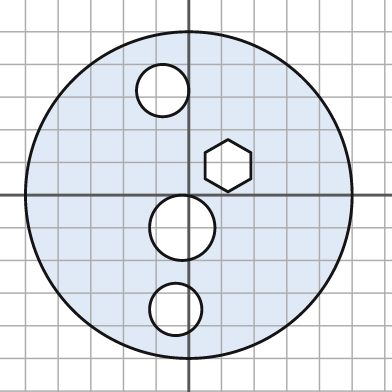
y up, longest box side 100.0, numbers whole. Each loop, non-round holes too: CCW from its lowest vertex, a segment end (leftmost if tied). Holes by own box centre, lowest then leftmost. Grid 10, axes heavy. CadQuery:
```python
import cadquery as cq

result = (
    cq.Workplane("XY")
    .moveTo(0.0, 0.0)
    .circle(50.0)
    .moveTo(-4.0, -35.0)
    .circle(8.0)
    .moveTo(-2.0, -10.0)
    .circle(10.0)
    .moveTo(12.0, 1.0)
    .lineTo(19.0, 5.0)
    .lineTo(19.0, 13.0)
    .lineTo(12.0, 17.0)
    .lineTo(5.0, 13.0)
    .lineTo(5.0, 5.0)
    .close()
    .moveTo(-8.0, 32.0)
    .circle(8.0)
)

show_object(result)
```